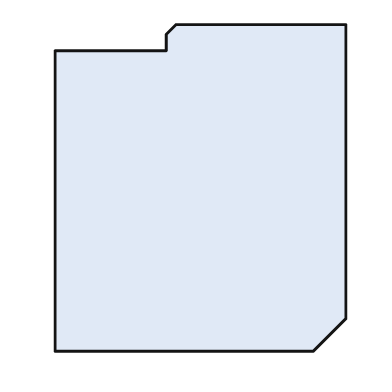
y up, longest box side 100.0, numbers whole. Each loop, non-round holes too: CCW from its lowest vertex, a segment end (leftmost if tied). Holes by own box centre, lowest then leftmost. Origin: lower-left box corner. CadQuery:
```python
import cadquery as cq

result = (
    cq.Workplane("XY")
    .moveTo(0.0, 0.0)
    .lineTo(79.0, 0.0)
    .lineTo(89.0, 10.0)
    .lineTo(89.0, 100.0)
    .lineTo(37.0, 100.0)
    .lineTo(34.0, 97.0)
    .lineTo(34.0, 92.0)
    .lineTo(0.0, 92.0)
    .close()
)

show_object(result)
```